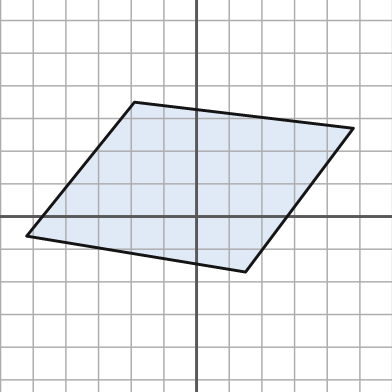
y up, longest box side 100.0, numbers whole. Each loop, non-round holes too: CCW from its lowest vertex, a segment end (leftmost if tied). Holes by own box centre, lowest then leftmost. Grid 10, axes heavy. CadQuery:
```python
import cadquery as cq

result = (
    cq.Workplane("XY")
    .moveTo(15.0, -17.0)
    .lineTo(48.0, 27.0)
    .lineTo(-19.0, 35.0)
    .lineTo(-52.0, -6.0)
    .close()
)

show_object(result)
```